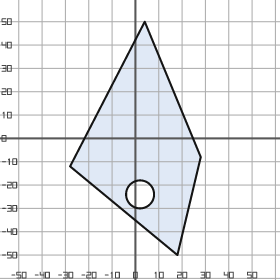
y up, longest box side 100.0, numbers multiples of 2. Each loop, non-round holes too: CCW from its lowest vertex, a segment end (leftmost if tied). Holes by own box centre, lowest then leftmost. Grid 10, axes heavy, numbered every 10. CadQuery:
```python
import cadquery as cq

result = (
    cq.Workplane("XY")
    .moveTo(18.0, -50.0)
    .lineTo(28.0, -8.0)
    .lineTo(4.0, 50.0)
    .lineTo(-28.0, -12.0)
    .close()
    .moveTo(2.0, -24.0)
    .circle(6.0)
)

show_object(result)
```